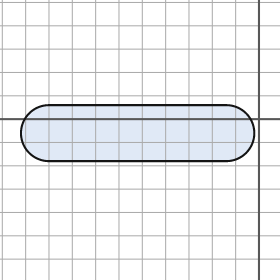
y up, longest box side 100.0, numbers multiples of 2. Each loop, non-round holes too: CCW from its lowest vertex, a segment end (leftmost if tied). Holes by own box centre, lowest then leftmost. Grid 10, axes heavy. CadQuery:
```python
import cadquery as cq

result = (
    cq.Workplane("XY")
    .moveTo(-90.0, -18.0)
    .lineTo(-14.0, -18.0)
    .threePointArc((-2.0, -6.0), (-14.0, 6.0))
    .lineTo(-90.0, 6.0)
    .threePointArc((-102.0, -6.0), (-90.0, -18.0))
    .close()
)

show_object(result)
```